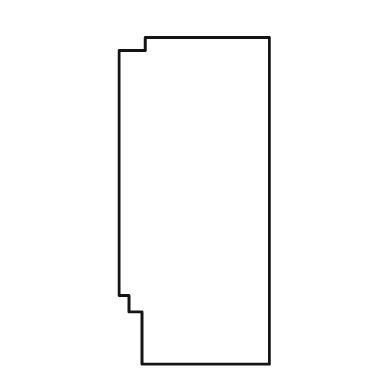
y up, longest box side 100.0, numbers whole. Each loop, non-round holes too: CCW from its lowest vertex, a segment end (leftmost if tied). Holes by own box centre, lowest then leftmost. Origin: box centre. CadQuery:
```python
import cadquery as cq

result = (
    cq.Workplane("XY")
    .moveTo(-16.0, -50.0)
    .lineTo(23.0, -50.0)
    .lineTo(23.0, 50.0)
    .lineTo(-15.0, 50.0)
    .lineTo(-15.0, 46.0)
    .lineTo(-23.0, 46.0)
    .lineTo(-23.0, -29.0)
    .lineTo(-20.0, -29.0)
    .lineTo(-20.0, -34.0)
    .lineTo(-16.0, -34.0)
    .close()
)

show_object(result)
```